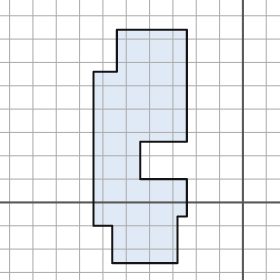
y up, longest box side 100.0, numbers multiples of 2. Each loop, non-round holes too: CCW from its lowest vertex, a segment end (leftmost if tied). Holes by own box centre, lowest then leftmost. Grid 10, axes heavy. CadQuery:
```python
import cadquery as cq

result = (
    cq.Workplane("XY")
    .moveTo(-56.0, -26.0)
    .lineTo(-28.0, -26.0)
    .lineTo(-28.0, -6.0)
    .lineTo(-24.0, -6.0)
    .lineTo(-24.0, 10.0)
    .lineTo(-44.0, 10.0)
    .lineTo(-44.0, 26.0)
    .lineTo(-24.0, 26.0)
    .lineTo(-24.0, 74.0)
    .lineTo(-54.0, 74.0)
    .lineTo(-54.0, 56.0)
    .lineTo(-64.0, 56.0)
    .lineTo(-64.0, -10.0)
    .lineTo(-56.0, -10.0)
    .close()
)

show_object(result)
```